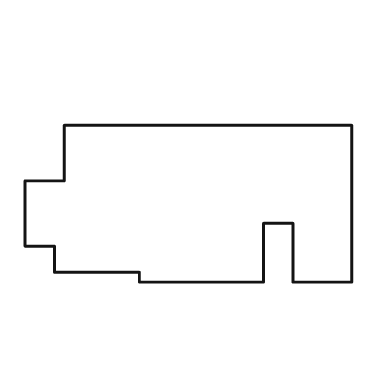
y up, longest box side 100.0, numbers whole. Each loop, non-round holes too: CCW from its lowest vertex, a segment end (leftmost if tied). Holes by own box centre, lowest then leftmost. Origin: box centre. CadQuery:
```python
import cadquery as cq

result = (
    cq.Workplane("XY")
    .moveTo(-15.0, -24.0)
    .lineTo(23.0, -24.0)
    .lineTo(23.0, -6.0)
    .lineTo(32.0, -6.0)
    .lineTo(32.0, -24.0)
    .lineTo(50.0, -24.0)
    .lineTo(50.0, 24.0)
    .lineTo(-38.0, 24.0)
    .lineTo(-38.0, 7.0)
    .lineTo(-50.0, 7.0)
    .lineTo(-50.0, -13.0)
    .lineTo(-41.0, -13.0)
    .lineTo(-41.0, -21.0)
    .lineTo(-15.0, -21.0)
    .close()
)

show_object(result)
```